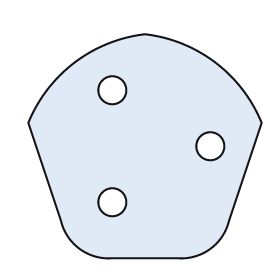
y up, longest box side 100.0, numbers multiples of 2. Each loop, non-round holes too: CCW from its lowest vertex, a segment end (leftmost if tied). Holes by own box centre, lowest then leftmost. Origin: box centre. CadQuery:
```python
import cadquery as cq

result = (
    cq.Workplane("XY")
    .moveTo(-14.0, -48.0)
    .lineTo(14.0, -48.0)
    .threePointArc((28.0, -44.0), (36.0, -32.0))
    .lineTo(50.0, 10.0)
    .threePointArc((30.0, 36.0), (0.0, 48.0))
    .threePointArc((-30.0, 36.0), (-50.0, 10.0))
    .lineTo(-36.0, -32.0)
    .threePointArc((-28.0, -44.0), (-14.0, -48.0))
    .close()
    .moveTo(-14.0, -24.0)
    .circle(6.0)
    .moveTo(28.0, 0.0)
    .circle(6.0)
    .moveTo(-14.0, 24.0)
    .circle(6.0)
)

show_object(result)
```